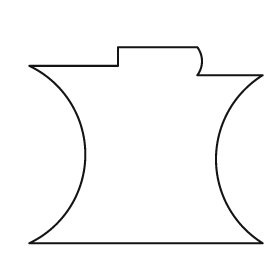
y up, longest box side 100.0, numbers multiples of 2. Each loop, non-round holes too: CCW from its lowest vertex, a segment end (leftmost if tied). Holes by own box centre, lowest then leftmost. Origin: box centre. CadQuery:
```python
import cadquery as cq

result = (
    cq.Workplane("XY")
    .moveTo(-50.0, -42.0)
    .lineTo(50.0, -42.0)
    .threePointArc((30.0, -6.0), (50.0, 30.0))
    .lineTo(22.0, 30.0)
    .threePointArc((24.0, 36.0), (22.0, 42.0))
    .lineTo(-12.0, 42.0)
    .lineTo(-12.0, 34.0)
    .lineTo(-50.0, 34.0)
    .threePointArc((-26.0, -4.0), (-50.0, -42.0))
    .close()
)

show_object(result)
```